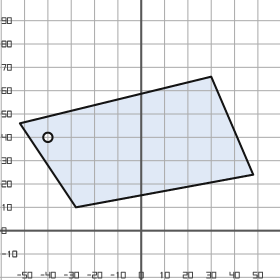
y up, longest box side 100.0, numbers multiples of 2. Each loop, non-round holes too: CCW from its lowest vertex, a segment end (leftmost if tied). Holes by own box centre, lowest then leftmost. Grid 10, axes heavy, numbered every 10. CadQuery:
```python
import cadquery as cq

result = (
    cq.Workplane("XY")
    .moveTo(-28.0, 10.0)
    .lineTo(48.0, 24.0)
    .lineTo(30.0, 66.0)
    .lineTo(-52.0, 46.0)
    .close()
    .moveTo(-40.0, 40.0)
    .circle(2.0)
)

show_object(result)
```